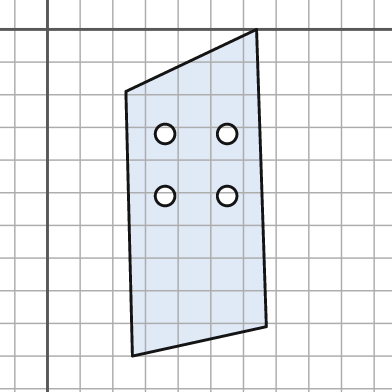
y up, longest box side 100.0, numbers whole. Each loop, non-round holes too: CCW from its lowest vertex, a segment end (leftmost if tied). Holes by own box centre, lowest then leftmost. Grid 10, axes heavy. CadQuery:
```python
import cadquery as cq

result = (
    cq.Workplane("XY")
    .moveTo(26.0, -100.0)
    .lineTo(67.0, -91.0)
    .lineTo(64.0, 0.0)
    .lineTo(24.0, -19.0)
    .close()
    .moveTo(36.0, -51.0)
    .circle(3.0)
    .moveTo(55.0, -51.0)
    .circle(3.0)
    .moveTo(36.0, -32.0)
    .circle(3.0)
    .moveTo(55.0, -32.0)
    .circle(3.0)
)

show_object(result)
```